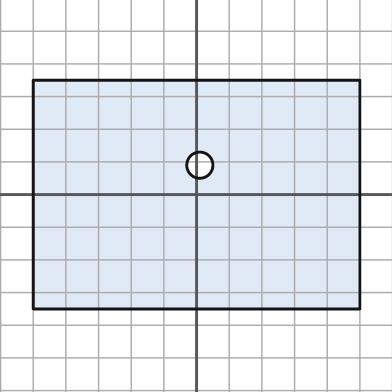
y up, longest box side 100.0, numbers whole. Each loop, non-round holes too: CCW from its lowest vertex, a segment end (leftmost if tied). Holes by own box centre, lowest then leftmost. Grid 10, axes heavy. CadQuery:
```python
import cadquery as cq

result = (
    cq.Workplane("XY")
    .moveTo(-50.0, -35.0)
    .lineTo(50.0, -35.0)
    .lineTo(50.0, 35.0)
    .lineTo(-50.0, 35.0)
    .close()
    .moveTo(1.0, 9.0)
    .circle(4.0)
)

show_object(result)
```